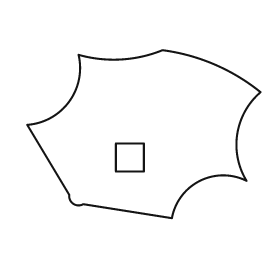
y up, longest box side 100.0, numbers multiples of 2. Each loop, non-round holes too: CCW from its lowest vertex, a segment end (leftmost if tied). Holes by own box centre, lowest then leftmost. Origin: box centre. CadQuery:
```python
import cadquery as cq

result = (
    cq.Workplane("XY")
    .moveTo(12.0, -36.0)
    .threePointArc((24.0, -20.0), (44.0, -20.0))
    .threePointArc((40.0, 0.0), (50.0, 18.0))
    .threePointArc((30.0, 30.0), (8.0, 36.0))
    .threePointArc((-10.0, 32.0), (-28.0, 34.0))
    .threePointArc((-32.0, 14.0), (-50.0, 4.0))
    .lineTo(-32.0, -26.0)
    .threePointArc((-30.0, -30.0), (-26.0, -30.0))
    .close()
    .moveTo(-12.0, -16.0)
    .lineTo(0.0, -16.0)
    .lineTo(0.0, -4.0)
    .lineTo(-12.0, -4.0)
    .close()
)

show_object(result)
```